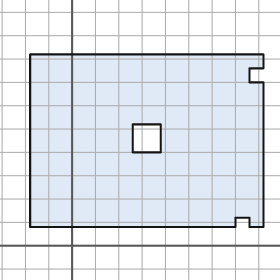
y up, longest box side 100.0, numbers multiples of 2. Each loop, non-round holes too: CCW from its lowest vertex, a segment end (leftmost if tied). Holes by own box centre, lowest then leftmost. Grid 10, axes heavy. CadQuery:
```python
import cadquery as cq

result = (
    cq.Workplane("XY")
    .moveTo(-18.0, 8.0)
    .lineTo(70.0, 8.0)
    .lineTo(70.0, 12.0)
    .lineTo(76.0, 12.0)
    .lineTo(76.0, 8.0)
    .lineTo(82.0, 8.0)
    .lineTo(82.0, 70.0)
    .lineTo(76.0, 70.0)
    .lineTo(76.0, 76.0)
    .lineTo(82.0, 76.0)
    .lineTo(82.0, 82.0)
    .lineTo(-18.0, 82.0)
    .close()
    .moveTo(26.0, 40.0)
    .lineTo(38.0, 40.0)
    .lineTo(38.0, 52.0)
    .lineTo(26.0, 52.0)
    .close()
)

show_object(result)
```